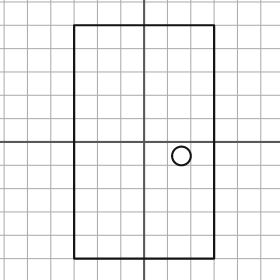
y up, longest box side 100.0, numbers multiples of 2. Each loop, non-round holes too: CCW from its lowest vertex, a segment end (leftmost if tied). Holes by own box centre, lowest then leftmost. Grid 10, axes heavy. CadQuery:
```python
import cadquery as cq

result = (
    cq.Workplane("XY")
    .moveTo(-30.0, -50.0)
    .lineTo(30.0, -50.0)
    .lineTo(30.0, 50.0)
    .lineTo(-30.0, 50.0)
    .close()
    .moveTo(16.0, -6.0)
    .circle(4.0)
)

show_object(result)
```